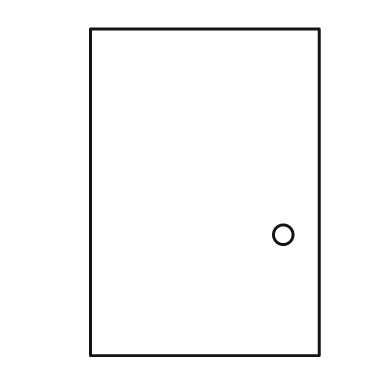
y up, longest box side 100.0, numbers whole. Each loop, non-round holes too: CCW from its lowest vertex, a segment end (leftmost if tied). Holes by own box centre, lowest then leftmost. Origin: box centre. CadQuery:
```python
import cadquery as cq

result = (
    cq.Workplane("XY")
    .moveTo(-35.0, -50.0)
    .lineTo(35.0, -50.0)
    .lineTo(35.0, 50.0)
    .lineTo(-35.0, 50.0)
    .close()
    .moveTo(24.0, -13.0)
    .circle(3.0)
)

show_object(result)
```